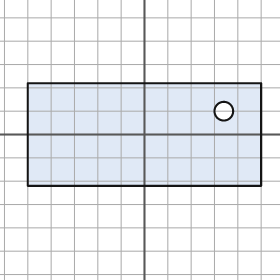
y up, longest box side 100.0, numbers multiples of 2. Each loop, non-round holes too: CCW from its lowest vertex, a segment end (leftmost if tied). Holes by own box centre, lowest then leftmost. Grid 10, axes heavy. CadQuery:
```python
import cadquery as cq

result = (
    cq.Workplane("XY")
    .moveTo(-50.0, -22.0)
    .lineTo(50.0, -22.0)
    .lineTo(50.0, 22.0)
    .lineTo(-50.0, 22.0)
    .close()
    .moveTo(34.0, 10.0)
    .circle(4.0)
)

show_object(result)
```